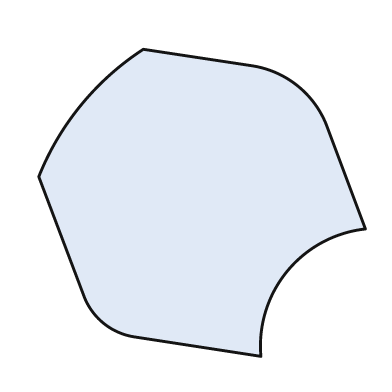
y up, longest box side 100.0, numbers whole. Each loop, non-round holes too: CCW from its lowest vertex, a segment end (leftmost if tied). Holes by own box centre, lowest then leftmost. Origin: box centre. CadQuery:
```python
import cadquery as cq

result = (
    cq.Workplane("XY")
    .moveTo(18.0, -47.0)
    .threePointArc((26.0, -21.0), (50.0, -8.0))
    .lineTo(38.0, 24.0)
    .threePointArc((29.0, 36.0), (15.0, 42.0))
    .lineTo(-18.0, 47.0)
    .threePointArc((-37.0, 30.0), (-50.0, 8.0))
    .lineTo(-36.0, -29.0)
    .threePointArc((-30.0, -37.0), (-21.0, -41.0))
    .close()
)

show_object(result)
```